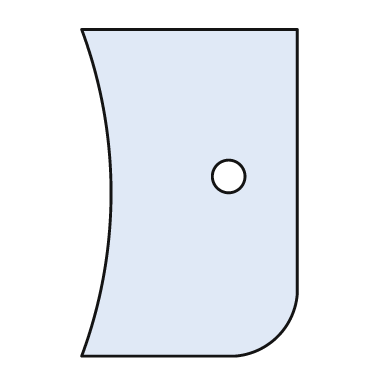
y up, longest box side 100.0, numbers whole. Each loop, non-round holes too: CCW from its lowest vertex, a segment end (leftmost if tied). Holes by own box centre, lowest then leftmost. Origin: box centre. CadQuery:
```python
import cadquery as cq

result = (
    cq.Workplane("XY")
    .moveTo(-33.0, -50.0)
    .lineTo(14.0, -50.0)
    .threePointArc((27.0, -44.0), (33.0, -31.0))
    .lineTo(33.0, 50.0)
    .lineTo(-33.0, 50.0)
    .threePointArc((-24.0, 0.0), (-33.0, -50.0))
    .close()
    .moveTo(12.0, 5.0)
    .circle(5.0)
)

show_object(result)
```